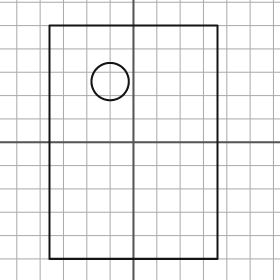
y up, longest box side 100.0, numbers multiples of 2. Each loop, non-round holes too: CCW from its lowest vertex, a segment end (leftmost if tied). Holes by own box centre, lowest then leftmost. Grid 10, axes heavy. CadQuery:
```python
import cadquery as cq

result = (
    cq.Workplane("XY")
    .moveTo(-36.0, -50.0)
    .lineTo(36.0, -50.0)
    .lineTo(36.0, 50.0)
    .lineTo(-36.0, 50.0)
    .close()
    .moveTo(-10.0, 26.0)
    .circle(8.0)
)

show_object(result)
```